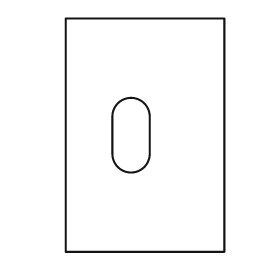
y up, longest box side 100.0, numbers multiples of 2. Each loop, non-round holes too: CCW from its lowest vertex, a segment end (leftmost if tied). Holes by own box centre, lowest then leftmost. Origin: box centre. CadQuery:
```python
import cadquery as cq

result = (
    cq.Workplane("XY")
    .moveTo(-34.0, -50.0)
    .lineTo(34.0, -50.0)
    .lineTo(34.0, 50.0)
    .lineTo(-34.0, 50.0)
    .close()
    .moveTo(-14.0, -8.0)
    .threePointArc((-6.0, -16.0), (2.0, -8.0))
    .lineTo(2.0, 8.0)
    .threePointArc((-6.0, 16.0), (-14.0, 8.0))
    .close()
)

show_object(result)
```